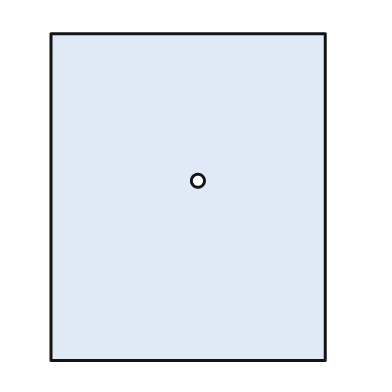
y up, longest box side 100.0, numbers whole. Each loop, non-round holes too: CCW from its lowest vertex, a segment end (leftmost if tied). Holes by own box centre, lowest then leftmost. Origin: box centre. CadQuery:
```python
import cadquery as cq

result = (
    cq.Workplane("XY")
    .moveTo(-42.0, -50.0)
    .lineTo(42.0, -50.0)
    .lineTo(42.0, 50.0)
    .lineTo(-42.0, 50.0)
    .close()
    .moveTo(3.0, 5.0)
    .circle(2.0)
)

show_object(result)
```